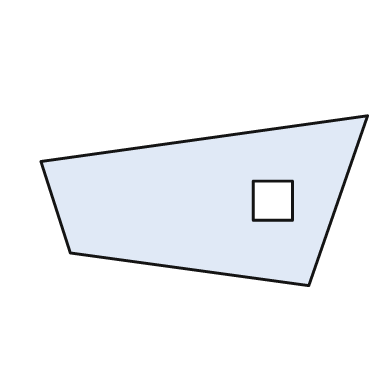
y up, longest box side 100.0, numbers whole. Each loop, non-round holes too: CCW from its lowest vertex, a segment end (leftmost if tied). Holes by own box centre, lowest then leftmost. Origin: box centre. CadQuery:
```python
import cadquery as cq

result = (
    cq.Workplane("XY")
    .moveTo(32.0, -26.0)
    .lineTo(50.0, 26.0)
    .lineTo(-50.0, 12.0)
    .lineTo(-41.0, -16.0)
    .close()
    .moveTo(15.0, -6.0)
    .lineTo(27.0, -6.0)
    .lineTo(27.0, 6.0)
    .lineTo(15.0, 6.0)
    .close()
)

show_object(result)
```